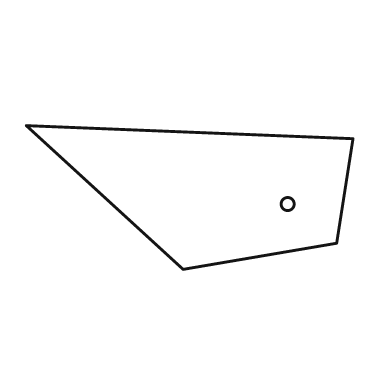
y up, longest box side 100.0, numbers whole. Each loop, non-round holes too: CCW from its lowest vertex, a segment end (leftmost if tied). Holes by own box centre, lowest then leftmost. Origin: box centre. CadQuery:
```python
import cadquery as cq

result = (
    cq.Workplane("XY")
    .moveTo(-2.0, -22.0)
    .lineTo(45.0, -14.0)
    .lineTo(50.0, 18.0)
    .lineTo(-50.0, 22.0)
    .close()
    .moveTo(30.0, -2.0)
    .circle(2.0)
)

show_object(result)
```